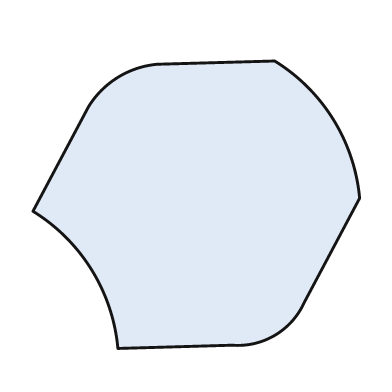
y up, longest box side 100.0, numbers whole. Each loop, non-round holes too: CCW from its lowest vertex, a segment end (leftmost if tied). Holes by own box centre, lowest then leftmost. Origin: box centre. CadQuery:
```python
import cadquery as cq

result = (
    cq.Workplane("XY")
    .moveTo(-24.0, -44.0)
    .lineTo(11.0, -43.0)
    .threePointArc((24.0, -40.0), (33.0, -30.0))
    .lineTo(50.0, 2.0)
    .threePointArc((42.0, 26.0), (24.0, 44.0))
    .lineTo(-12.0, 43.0)
    .threePointArc((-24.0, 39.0), (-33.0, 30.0))
    .lineTo(-50.0, -2.0)
    .threePointArc((-32.0, -20.0), (-24.0, -44.0))
    .close()
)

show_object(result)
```